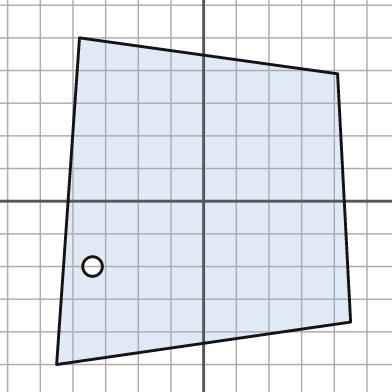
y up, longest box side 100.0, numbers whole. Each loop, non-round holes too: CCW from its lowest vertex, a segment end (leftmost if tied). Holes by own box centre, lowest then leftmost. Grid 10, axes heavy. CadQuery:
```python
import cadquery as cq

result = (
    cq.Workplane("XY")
    .moveTo(-45.0, -50.0)
    .lineTo(45.0, -37.0)
    .lineTo(41.0, 39.0)
    .lineTo(-38.0, 50.0)
    .close()
    .moveTo(-34.0, -20.0)
    .circle(3.0)
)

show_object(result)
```